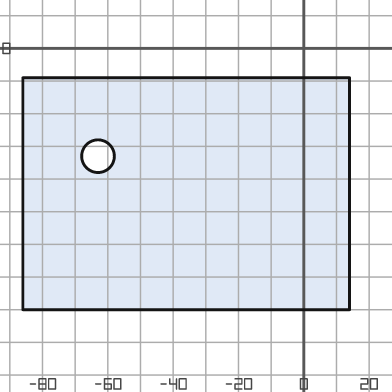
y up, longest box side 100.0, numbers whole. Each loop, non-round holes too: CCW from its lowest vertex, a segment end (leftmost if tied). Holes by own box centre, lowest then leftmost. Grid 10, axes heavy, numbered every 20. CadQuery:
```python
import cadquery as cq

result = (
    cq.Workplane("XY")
    .moveTo(-86.0, -80.0)
    .lineTo(14.0, -80.0)
    .lineTo(14.0, -9.0)
    .lineTo(-86.0, -9.0)
    .close()
    .moveTo(-63.0, -33.0)
    .circle(5.0)
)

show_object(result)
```